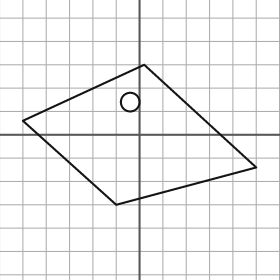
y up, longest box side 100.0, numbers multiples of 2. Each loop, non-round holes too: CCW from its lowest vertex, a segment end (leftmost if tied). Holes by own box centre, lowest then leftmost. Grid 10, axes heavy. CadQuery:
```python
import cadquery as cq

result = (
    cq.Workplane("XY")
    .moveTo(-10.0, -30.0)
    .lineTo(50.0, -14.0)
    .lineTo(2.0, 30.0)
    .lineTo(-50.0, 6.0)
    .close()
    .moveTo(-4.0, 14.0)
    .circle(4.0)
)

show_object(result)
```